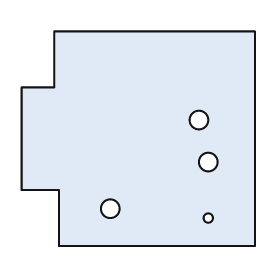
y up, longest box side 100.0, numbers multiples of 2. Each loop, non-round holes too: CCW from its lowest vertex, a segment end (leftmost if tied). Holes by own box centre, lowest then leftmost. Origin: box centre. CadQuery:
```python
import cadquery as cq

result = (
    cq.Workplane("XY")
    .moveTo(-34.0, -46.0)
    .lineTo(50.0, -46.0)
    .lineTo(50.0, 46.0)
    .lineTo(-36.0, 46.0)
    .lineTo(-36.0, 22.0)
    .lineTo(-50.0, 22.0)
    .lineTo(-50.0, -22.0)
    .lineTo(-34.0, -22.0)
    .close()
    .moveTo(30.0, -34.0)
    .circle(2.0)
    .moveTo(-12.0, -30.0)
    .circle(4.0)
    .moveTo(30.0, -10.0)
    .circle(4.0)
    .moveTo(26.0, 8.0)
    .circle(4.0)
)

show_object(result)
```